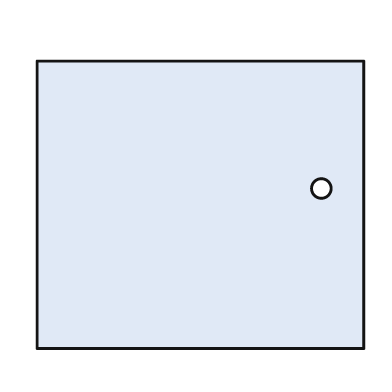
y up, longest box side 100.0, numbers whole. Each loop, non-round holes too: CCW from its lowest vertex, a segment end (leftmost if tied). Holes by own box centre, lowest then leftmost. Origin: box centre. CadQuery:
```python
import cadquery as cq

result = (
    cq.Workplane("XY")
    .moveTo(-50.0, -44.0)
    .lineTo(50.0, -44.0)
    .lineTo(50.0, 44.0)
    .lineTo(-50.0, 44.0)
    .close()
    .moveTo(37.0, 5.0)
    .circle(3.0)
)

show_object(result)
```